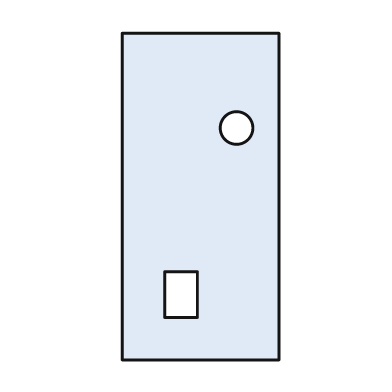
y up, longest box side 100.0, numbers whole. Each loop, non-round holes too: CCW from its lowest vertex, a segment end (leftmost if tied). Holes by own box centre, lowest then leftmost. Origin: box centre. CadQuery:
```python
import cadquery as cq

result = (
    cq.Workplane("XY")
    .moveTo(-24.0, -50.0)
    .lineTo(24.0, -50.0)
    .lineTo(24.0, 50.0)
    .lineTo(-24.0, 50.0)
    .close()
    .moveTo(-11.0, -37.0)
    .lineTo(-1.0, -37.0)
    .lineTo(-1.0, -23.0)
    .lineTo(-11.0, -23.0)
    .close()
    .moveTo(11.0, 21.0)
    .circle(5.0)
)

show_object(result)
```